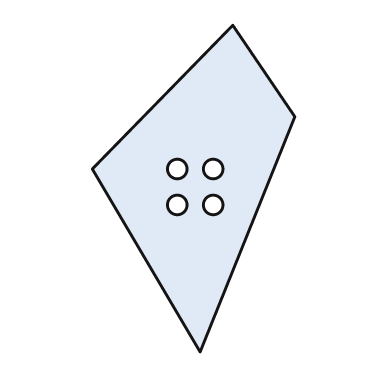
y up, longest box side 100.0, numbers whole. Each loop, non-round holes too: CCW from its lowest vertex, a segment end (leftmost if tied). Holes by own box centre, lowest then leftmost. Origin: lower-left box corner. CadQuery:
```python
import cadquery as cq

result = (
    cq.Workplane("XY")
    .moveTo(33.0, 0.0)
    .lineTo(62.0, 72.0)
    .lineTo(43.0, 100.0)
    .lineTo(0.0, 56.0)
    .close()
    .moveTo(26.0, 45.0)
    .circle(3.0)
    .moveTo(37.0, 45.0)
    .circle(3.0)
    .moveTo(26.0, 56.0)
    .circle(3.0)
    .moveTo(37.0, 56.0)
    .circle(3.0)
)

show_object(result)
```